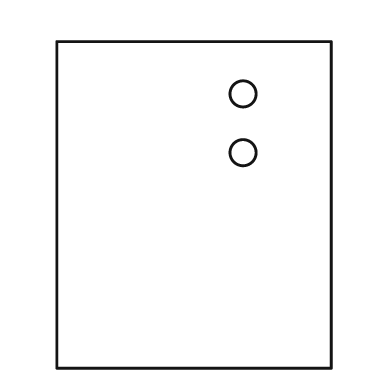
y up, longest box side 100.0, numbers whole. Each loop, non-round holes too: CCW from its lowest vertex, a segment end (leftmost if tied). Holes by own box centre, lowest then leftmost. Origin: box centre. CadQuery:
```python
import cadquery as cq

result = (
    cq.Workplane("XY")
    .moveTo(-42.0, -50.0)
    .lineTo(42.0, -50.0)
    .lineTo(42.0, 50.0)
    .lineTo(-42.0, 50.0)
    .close()
    .moveTo(15.0, 16.0)
    .circle(4.0)
    .moveTo(15.0, 34.0)
    .circle(4.0)
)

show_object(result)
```